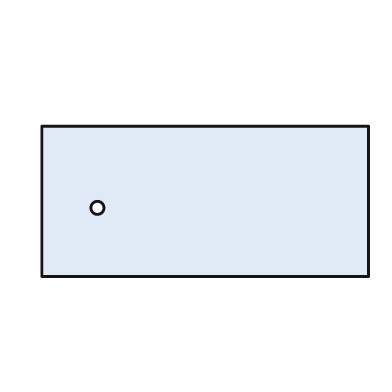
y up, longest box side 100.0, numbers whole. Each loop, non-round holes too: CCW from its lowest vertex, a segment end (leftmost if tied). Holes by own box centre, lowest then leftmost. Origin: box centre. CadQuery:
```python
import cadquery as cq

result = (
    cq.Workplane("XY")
    .moveTo(-50.0, -23.0)
    .lineTo(50.0, -23.0)
    .lineTo(50.0, 23.0)
    .lineTo(-50.0, 23.0)
    .close()
    .moveTo(-33.0, -2.0)
    .circle(2.0)
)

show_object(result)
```